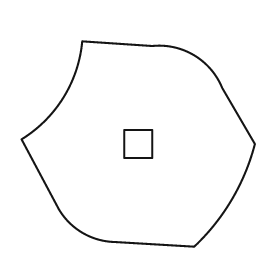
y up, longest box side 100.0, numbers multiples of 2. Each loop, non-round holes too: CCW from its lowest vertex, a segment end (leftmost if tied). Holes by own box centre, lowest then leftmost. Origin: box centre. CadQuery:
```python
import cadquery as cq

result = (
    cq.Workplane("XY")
    .moveTo(24.0, -44.0)
    .threePointArc((40.0, -24.0), (50.0, 0.0))
    .lineTo(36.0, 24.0)
    .threePointArc((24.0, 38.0), (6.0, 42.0))
    .lineTo(-24.0, 44.0)
    .threePointArc((-32.0, 20.0), (-50.0, 2.0))
    .lineTo(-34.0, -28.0)
    .threePointArc((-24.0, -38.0), (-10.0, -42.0))
    .close()
    .moveTo(-6.0, -6.0)
    .lineTo(6.0, -6.0)
    .lineTo(6.0, 6.0)
    .lineTo(-6.0, 6.0)
    .close()
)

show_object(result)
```